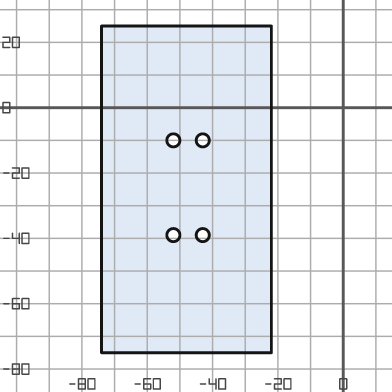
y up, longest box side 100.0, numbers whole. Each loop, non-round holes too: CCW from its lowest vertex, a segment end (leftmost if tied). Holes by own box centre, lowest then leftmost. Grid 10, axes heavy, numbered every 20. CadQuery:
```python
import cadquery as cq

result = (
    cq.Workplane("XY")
    .moveTo(-74.0, -75.0)
    .lineTo(-22.0, -75.0)
    .lineTo(-22.0, 25.0)
    .lineTo(-74.0, 25.0)
    .close()
    .moveTo(-52.0, -39.0)
    .circle(2.0)
    .moveTo(-43.0, -39.0)
    .circle(2.0)
    .moveTo(-52.0, -10.0)
    .circle(2.0)
    .moveTo(-43.0, -10.0)
    .circle(2.0)
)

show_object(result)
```